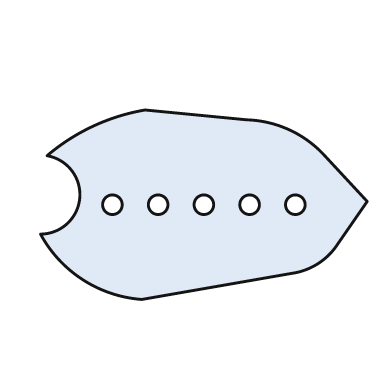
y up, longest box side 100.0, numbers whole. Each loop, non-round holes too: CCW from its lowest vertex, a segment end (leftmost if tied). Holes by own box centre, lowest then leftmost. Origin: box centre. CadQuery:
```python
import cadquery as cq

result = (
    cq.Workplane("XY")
    .moveTo(-19.0, -29.0)
    .lineTo(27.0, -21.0)
    .threePointArc((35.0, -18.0), (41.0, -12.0))
    .lineTo(50.0, 1.0)
    .lineTo(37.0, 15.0)
    .threePointArc((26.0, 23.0), (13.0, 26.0))
    .lineTo(-18.0, 29.0)
    .threePointArc((-34.0, 24.0), (-48.0, 15.0))
    .threePointArc((-38.0, 2.0), (-50.0, -9.0))
    .threePointArc((-37.0, -23.0), (-19.0, -29.0))
    .close()
    .moveTo(-28.0, 0.0)
    .circle(3.0)
    .moveTo(-14.0, 0.0)
    .circle(3.0)
    .moveTo(0.0, 0.0)
    .circle(3.0)
    .moveTo(14.0, 0.0)
    .circle(3.0)
    .moveTo(28.0, 0.0)
    .circle(3.0)
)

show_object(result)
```